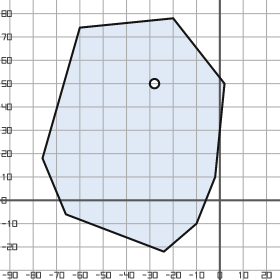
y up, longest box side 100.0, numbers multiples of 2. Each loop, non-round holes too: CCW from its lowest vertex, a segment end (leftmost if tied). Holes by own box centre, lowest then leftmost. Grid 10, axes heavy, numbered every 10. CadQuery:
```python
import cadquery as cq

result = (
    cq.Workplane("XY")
    .moveTo(-24.0, -22.0)
    .lineTo(-10.0, -10.0)
    .lineTo(-2.0, 10.0)
    .lineTo(2.0, 50.0)
    .lineTo(-20.0, 78.0)
    .lineTo(-60.0, 74.0)
    .lineTo(-76.0, 18.0)
    .lineTo(-66.0, -6.0)
    .close()
    .moveTo(-28.0, 50.0)
    .circle(2.0)
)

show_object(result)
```